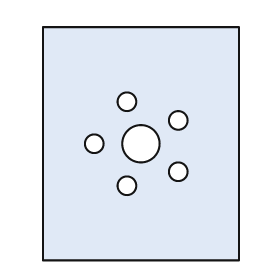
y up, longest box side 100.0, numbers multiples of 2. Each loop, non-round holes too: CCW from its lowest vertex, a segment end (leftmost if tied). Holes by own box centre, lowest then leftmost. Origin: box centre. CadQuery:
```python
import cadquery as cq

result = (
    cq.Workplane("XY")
    .moveTo(-42.0, -50.0)
    .lineTo(42.0, -50.0)
    .lineTo(42.0, 50.0)
    .lineTo(-42.0, 50.0)
    .close()
    .moveTo(-6.0, -18.0)
    .circle(4.0)
    .moveTo(16.0, -12.0)
    .circle(4.0)
    .moveTo(-20.0, 0.0)
    .circle(4.0)
    .moveTo(0.0, 0.0)
    .circle(8.0)
    .moveTo(16.0, 10.0)
    .circle(4.0)
    .moveTo(-6.0, 18.0)
    .circle(4.0)
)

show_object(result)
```